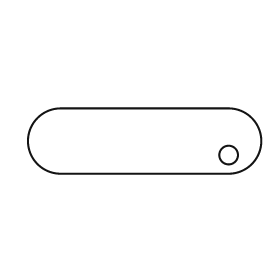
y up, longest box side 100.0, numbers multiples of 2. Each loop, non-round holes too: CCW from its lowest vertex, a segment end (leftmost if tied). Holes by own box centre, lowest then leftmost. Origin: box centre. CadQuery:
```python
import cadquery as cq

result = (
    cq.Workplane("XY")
    .moveTo(-36.0, -14.0)
    .lineTo(36.0, -14.0)
    .threePointArc((50.0, 0.0), (36.0, 14.0))
    .lineTo(-36.0, 14.0)
    .threePointArc((-50.0, 0.0), (-36.0, -14.0))
    .close()
    .moveTo(36.0, -6.0)
    .circle(4.0)
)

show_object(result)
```